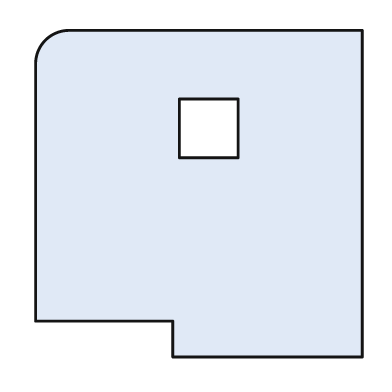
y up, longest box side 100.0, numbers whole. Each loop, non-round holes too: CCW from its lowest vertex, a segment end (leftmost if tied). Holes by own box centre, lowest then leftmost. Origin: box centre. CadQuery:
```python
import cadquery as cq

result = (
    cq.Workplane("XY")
    .moveTo(-8.0, -50.0)
    .lineTo(50.0, -50.0)
    .lineTo(50.0, 50.0)
    .lineTo(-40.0, 50.0)
    .threePointArc((-47.0, 47.0), (-50.0, 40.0))
    .lineTo(-50.0, -39.0)
    .lineTo(-8.0, -39.0)
    .close()
    .moveTo(-6.0, 11.0)
    .lineTo(12.0, 11.0)
    .lineTo(12.0, 29.0)
    .lineTo(-6.0, 29.0)
    .close()
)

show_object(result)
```